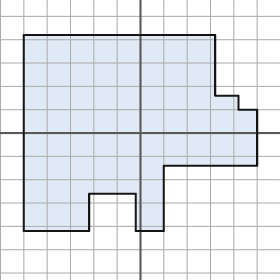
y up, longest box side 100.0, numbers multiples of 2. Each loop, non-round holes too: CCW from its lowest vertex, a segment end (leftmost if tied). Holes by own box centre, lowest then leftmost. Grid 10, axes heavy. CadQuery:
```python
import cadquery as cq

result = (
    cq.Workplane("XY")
    .moveTo(-50.0, -42.0)
    .lineTo(-22.0, -42.0)
    .lineTo(-22.0, -26.0)
    .lineTo(-2.0, -26.0)
    .lineTo(-2.0, -42.0)
    .lineTo(10.0, -42.0)
    .lineTo(10.0, -14.0)
    .lineTo(50.0, -14.0)
    .lineTo(50.0, 10.0)
    .lineTo(42.0, 10.0)
    .lineTo(42.0, 16.0)
    .lineTo(32.0, 16.0)
    .lineTo(32.0, 42.0)
    .lineTo(-50.0, 42.0)
    .close()
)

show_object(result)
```